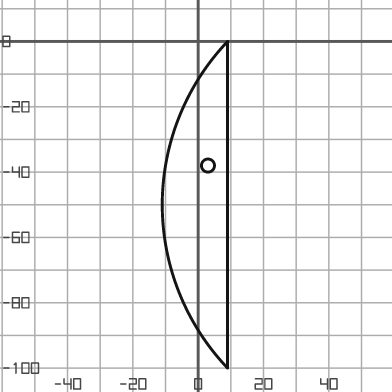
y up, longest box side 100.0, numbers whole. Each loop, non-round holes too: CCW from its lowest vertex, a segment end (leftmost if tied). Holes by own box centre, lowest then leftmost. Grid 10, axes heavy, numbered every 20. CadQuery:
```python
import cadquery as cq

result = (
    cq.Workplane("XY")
    .moveTo(9.0, -100.0)
    .lineTo(9.0, 0.0)
    .threePointArc((-11.0, -50.0), (9.0, -100.0))
    .close()
    .moveTo(3.0, -38.0)
    .circle(2.0)
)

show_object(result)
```